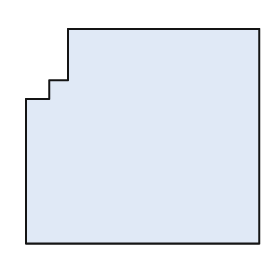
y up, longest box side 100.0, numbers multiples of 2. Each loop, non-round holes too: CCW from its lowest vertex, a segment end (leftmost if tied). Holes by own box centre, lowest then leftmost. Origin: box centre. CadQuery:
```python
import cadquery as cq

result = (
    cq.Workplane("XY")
    .moveTo(-50.0, -46.0)
    .lineTo(50.0, -46.0)
    .lineTo(50.0, 46.0)
    .lineTo(-32.0, 46.0)
    .lineTo(-32.0, 24.0)
    .lineTo(-40.0, 24.0)
    .lineTo(-40.0, 16.0)
    .lineTo(-50.0, 16.0)
    .close()
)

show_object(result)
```